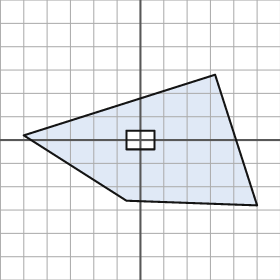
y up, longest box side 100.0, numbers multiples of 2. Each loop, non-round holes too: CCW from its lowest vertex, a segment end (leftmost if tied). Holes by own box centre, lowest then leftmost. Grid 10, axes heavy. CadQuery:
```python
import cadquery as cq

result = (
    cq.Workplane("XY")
    .moveTo(50.0, -28.0)
    .lineTo(32.0, 28.0)
    .lineTo(-50.0, 2.0)
    .lineTo(-6.0, -26.0)
    .close()
    .moveTo(-6.0, -4.0)
    .lineTo(6.0, -4.0)
    .lineTo(6.0, 4.0)
    .lineTo(-6.0, 4.0)
    .close()
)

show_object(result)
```